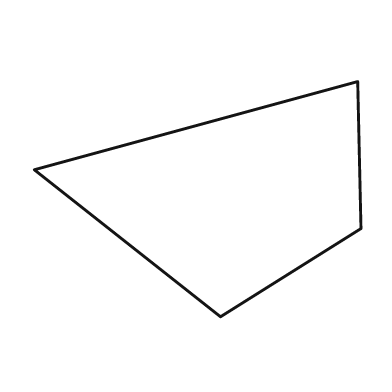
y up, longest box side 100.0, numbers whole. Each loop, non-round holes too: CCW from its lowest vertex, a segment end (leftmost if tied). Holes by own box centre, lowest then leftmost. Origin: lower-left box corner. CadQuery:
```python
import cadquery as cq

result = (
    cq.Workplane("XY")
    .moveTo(57.0, 0.0)
    .lineTo(100.0, 27.0)
    .lineTo(99.0, 72.0)
    .lineTo(0.0, 45.0)
    .close()
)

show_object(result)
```